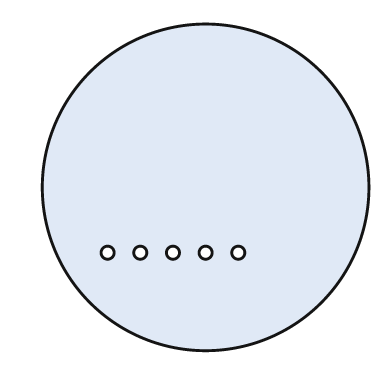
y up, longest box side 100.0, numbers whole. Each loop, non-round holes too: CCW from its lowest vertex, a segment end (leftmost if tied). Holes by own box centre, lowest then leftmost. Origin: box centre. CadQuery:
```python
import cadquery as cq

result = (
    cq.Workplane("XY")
    .moveTo(0.0, 0.0)
    .circle(50.0)
    .moveTo(-30.0, -20.0)
    .circle(2.0)
    .moveTo(-20.0, -20.0)
    .circle(2.0)
    .moveTo(-10.0, -20.0)
    .circle(2.0)
    .moveTo(0.0, -20.0)
    .circle(2.0)
    .moveTo(10.0, -20.0)
    .circle(2.0)
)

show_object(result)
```